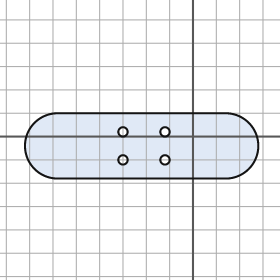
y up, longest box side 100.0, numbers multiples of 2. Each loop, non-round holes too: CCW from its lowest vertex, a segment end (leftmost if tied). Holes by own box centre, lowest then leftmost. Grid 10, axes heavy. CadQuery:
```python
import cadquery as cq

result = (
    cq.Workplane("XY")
    .moveTo(-58.0, -18.0)
    .lineTo(14.0, -18.0)
    .threePointArc((28.0, -4.0), (14.0, 10.0))
    .lineTo(-58.0, 10.0)
    .threePointArc((-72.0, -4.0), (-58.0, -18.0))
    .close()
    .moveTo(-30.0, -10.0)
    .circle(2.0)
    .moveTo(-12.0, -10.0)
    .circle(2.0)
    .moveTo(-30.0, 2.0)
    .circle(2.0)
    .moveTo(-12.0, 2.0)
    .circle(2.0)
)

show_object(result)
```